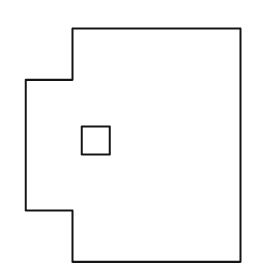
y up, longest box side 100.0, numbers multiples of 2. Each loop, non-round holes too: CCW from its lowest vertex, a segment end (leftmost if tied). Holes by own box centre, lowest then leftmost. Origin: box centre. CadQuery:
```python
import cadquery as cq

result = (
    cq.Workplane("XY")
    .moveTo(-26.0, -50.0)
    .lineTo(46.0, -50.0)
    .lineTo(46.0, 50.0)
    .lineTo(-26.0, 50.0)
    .lineTo(-26.0, 28.0)
    .lineTo(-46.0, 28.0)
    .lineTo(-46.0, -28.0)
    .lineTo(-26.0, -28.0)
    .close()
    .moveTo(-22.0, -4.0)
    .lineTo(-10.0, -4.0)
    .lineTo(-10.0, 8.0)
    .lineTo(-22.0, 8.0)
    .close()
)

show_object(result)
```